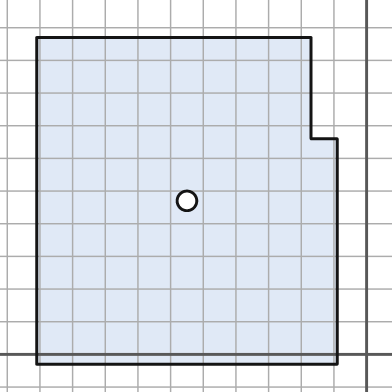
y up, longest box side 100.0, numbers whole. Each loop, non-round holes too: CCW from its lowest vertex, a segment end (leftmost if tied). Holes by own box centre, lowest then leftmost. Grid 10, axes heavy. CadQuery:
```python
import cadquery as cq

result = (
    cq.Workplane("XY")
    .moveTo(-101.0, -3.0)
    .lineTo(-9.0, -3.0)
    .lineTo(-9.0, 66.0)
    .lineTo(-17.0, 66.0)
    .lineTo(-17.0, 97.0)
    .lineTo(-101.0, 97.0)
    .close()
    .moveTo(-55.0, 47.0)
    .circle(3.0)
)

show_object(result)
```